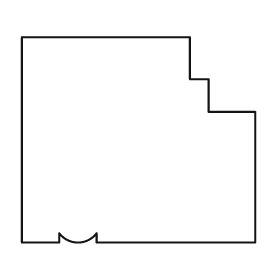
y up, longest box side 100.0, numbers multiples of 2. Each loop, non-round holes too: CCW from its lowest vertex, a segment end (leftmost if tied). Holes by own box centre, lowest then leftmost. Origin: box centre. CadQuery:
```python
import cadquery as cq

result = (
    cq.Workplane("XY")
    .moveTo(-50.0, -44.0)
    .lineTo(-34.0, -44.0)
    .lineTo(-34.0, -40.0)
    .threePointArc((-26.0, -44.0), (-18.0, -40.0))
    .lineTo(-18.0, -44.0)
    .lineTo(50.0, -44.0)
    .lineTo(50.0, 12.0)
    .lineTo(30.0, 12.0)
    .lineTo(30.0, 26.0)
    .lineTo(22.0, 26.0)
    .lineTo(22.0, 44.0)
    .lineTo(-50.0, 44.0)
    .close()
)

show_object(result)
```